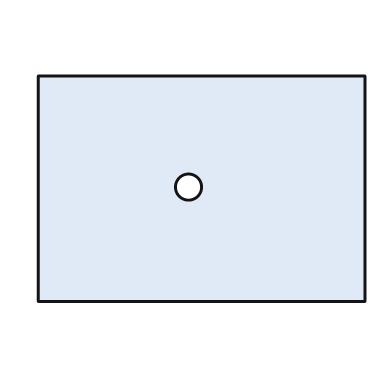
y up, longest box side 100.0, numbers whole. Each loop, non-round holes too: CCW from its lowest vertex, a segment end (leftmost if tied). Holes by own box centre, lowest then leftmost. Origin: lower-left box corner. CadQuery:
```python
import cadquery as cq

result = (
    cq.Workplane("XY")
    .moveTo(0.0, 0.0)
    .lineTo(100.0, 0.0)
    .lineTo(100.0, 69.0)
    .lineTo(0.0, 69.0)
    .close()
    .moveTo(46.0, 35.0)
    .circle(4.0)
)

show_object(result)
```